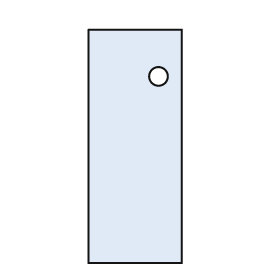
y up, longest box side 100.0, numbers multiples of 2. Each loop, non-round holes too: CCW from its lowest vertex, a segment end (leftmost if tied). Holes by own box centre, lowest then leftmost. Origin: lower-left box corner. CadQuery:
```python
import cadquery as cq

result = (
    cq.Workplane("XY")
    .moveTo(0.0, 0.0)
    .lineTo(40.0, 0.0)
    .lineTo(40.0, 100.0)
    .lineTo(0.0, 100.0)
    .close()
    .moveTo(30.0, 80.0)
    .circle(4.0)
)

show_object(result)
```